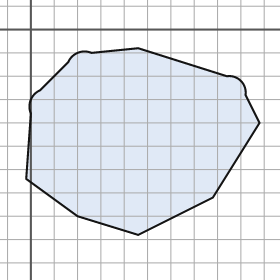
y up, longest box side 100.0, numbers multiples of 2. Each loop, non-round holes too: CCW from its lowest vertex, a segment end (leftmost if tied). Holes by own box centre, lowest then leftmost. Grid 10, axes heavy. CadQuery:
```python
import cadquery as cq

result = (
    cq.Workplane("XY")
    .moveTo(46.0, -88.0)
    .lineTo(78.0, -72.0)
    .lineTo(98.0, -40.0)
    .lineTo(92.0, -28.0)
    .threePointArc((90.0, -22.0), (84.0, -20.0))
    .lineTo(46.0, -8.0)
    .lineTo(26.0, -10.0)
    .threePointArc((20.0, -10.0), (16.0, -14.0))
    .lineTo(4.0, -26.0)
    .threePointArc((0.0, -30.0), (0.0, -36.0))
    .lineTo(-2.0, -64.0)
    .lineTo(20.0, -80.0)
    .close()
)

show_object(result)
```